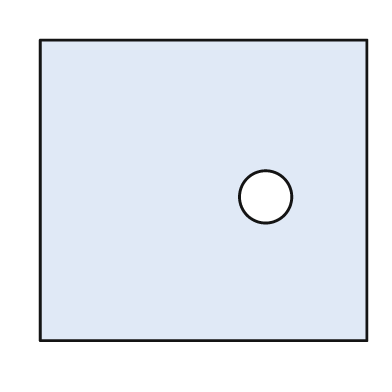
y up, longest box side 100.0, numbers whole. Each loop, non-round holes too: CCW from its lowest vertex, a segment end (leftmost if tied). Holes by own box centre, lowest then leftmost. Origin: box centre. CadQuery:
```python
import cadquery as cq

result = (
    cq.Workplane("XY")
    .moveTo(-50.0, -46.0)
    .lineTo(50.0, -46.0)
    .lineTo(50.0, 46.0)
    .lineTo(-50.0, 46.0)
    .close()
    .moveTo(19.0, -2.0)
    .circle(8.0)
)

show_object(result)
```